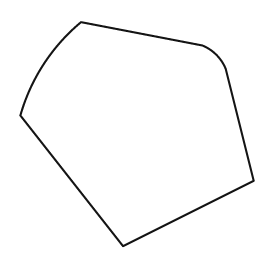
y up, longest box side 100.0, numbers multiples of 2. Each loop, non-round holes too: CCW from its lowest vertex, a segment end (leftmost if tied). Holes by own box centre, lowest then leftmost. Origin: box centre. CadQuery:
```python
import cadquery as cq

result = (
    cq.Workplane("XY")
    .moveTo(-6.0, -48.0)
    .lineTo(50.0, -20.0)
    .lineTo(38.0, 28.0)
    .threePointArc((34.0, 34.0), (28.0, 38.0))
    .lineTo(-24.0, 48.0)
    .threePointArc((-40.0, 30.0), (-50.0, 8.0))
    .close()
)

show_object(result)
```